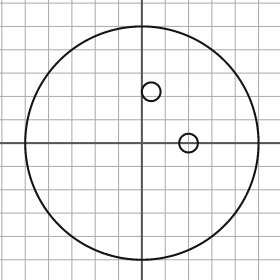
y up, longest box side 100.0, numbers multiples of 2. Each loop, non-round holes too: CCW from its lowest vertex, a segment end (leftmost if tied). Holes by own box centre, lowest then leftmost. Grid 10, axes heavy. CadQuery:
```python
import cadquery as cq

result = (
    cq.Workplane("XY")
    .moveTo(0.0, 0.0)
    .circle(50.0)
    .moveTo(20.0, 0.0)
    .circle(4.0)
    .moveTo(4.0, 22.0)
    .circle(4.0)
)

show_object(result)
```